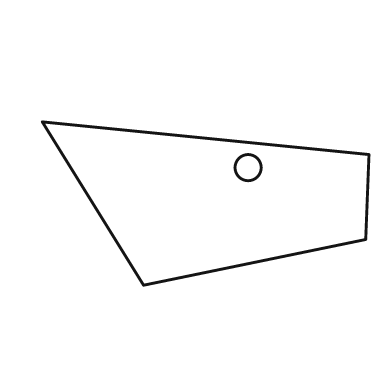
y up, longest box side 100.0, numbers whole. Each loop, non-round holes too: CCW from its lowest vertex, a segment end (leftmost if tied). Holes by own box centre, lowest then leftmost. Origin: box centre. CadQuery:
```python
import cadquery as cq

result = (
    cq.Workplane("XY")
    .moveTo(-19.0, -25.0)
    .lineTo(49.0, -11.0)
    .lineTo(50.0, 15.0)
    .lineTo(-50.0, 25.0)
    .close()
    .moveTo(13.0, 11.0)
    .circle(4.0)
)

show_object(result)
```